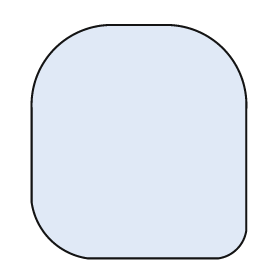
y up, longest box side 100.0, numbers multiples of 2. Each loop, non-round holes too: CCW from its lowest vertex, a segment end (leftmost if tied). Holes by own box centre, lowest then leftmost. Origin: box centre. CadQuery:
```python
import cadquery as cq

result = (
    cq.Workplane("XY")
    .moveTo(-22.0, -50.0)
    .lineTo(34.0, -50.0)
    .threePointArc((42.0, -46.0), (46.0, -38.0))
    .lineTo(46.0, 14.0)
    .threePointArc((36.0, 40.0), (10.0, 50.0))
    .lineTo(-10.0, 50.0)
    .threePointArc((-36.0, 40.0), (-46.0, 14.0))
    .lineTo(-46.0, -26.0)
    .threePointArc((-38.0, -42.0), (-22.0, -50.0))
    .close()
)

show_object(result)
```